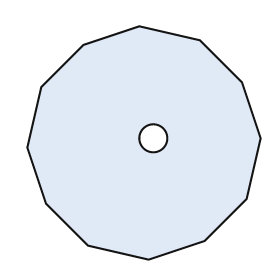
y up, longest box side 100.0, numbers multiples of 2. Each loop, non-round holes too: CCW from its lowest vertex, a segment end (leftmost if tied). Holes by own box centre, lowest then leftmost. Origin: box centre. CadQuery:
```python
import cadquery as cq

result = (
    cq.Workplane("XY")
    .moveTo(2.0, -50.0)
    .lineTo(26.0, -42.0)
    .lineTo(44.0, -24.0)
    .lineTo(50.0, 2.0)
    .lineTo(42.0, 26.0)
    .lineTo(24.0, 44.0)
    .lineTo(-2.0, 50.0)
    .lineTo(-26.0, 42.0)
    .lineTo(-44.0, 24.0)
    .lineTo(-50.0, -2.0)
    .lineTo(-42.0, -26.0)
    .lineTo(-24.0, -44.0)
    .close()
    .moveTo(4.0, 2.0)
    .circle(6.0)
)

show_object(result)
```